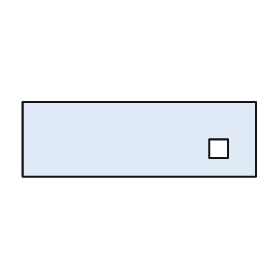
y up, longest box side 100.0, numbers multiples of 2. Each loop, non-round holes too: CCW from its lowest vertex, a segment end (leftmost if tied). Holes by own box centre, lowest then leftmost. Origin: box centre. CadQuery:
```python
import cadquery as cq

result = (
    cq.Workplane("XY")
    .moveTo(-50.0, -16.0)
    .lineTo(50.0, -16.0)
    .lineTo(50.0, 16.0)
    .lineTo(-50.0, 16.0)
    .close()
    .moveTo(30.0, -8.0)
    .lineTo(38.0, -8.0)
    .lineTo(38.0, 0.0)
    .lineTo(30.0, 0.0)
    .close()
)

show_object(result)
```